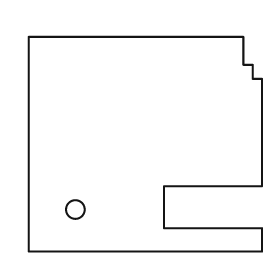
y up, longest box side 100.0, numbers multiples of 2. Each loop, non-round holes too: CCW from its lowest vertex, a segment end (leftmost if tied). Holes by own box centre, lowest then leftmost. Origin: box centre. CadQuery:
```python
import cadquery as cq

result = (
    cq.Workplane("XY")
    .moveTo(-50.0, -46.0)
    .lineTo(50.0, -46.0)
    .lineTo(50.0, -36.0)
    .lineTo(8.0, -36.0)
    .lineTo(8.0, -18.0)
    .lineTo(50.0, -18.0)
    .lineTo(50.0, 28.0)
    .lineTo(46.0, 28.0)
    .lineTo(46.0, 34.0)
    .lineTo(42.0, 34.0)
    .lineTo(42.0, 46.0)
    .lineTo(-50.0, 46.0)
    .close()
    .moveTo(-30.0, -28.0)
    .circle(4.0)
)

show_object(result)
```